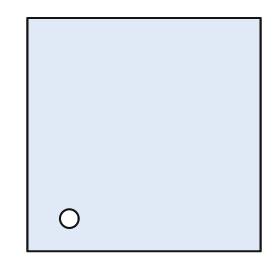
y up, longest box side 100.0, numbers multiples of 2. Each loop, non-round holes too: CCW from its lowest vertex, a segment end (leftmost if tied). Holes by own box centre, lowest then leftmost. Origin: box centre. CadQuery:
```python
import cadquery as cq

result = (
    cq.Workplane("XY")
    .moveTo(-50.0, -50.0)
    .lineTo(50.0, -50.0)
    .lineTo(50.0, 50.0)
    .lineTo(-50.0, 50.0)
    .close()
    .moveTo(-32.0, -36.0)
    .circle(4.0)
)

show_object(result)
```